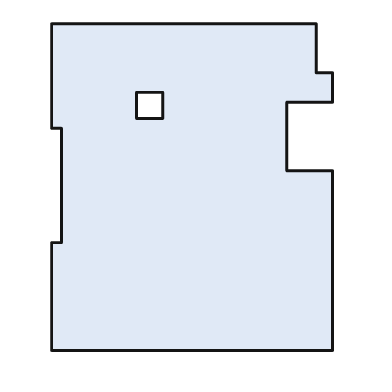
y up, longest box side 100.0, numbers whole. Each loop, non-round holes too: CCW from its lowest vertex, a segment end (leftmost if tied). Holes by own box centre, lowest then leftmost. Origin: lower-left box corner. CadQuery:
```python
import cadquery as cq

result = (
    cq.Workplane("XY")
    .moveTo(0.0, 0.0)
    .lineTo(86.0, 0.0)
    .lineTo(86.0, 55.0)
    .lineTo(72.0, 55.0)
    .lineTo(72.0, 76.0)
    .lineTo(86.0, 76.0)
    .lineTo(86.0, 85.0)
    .lineTo(81.0, 85.0)
    .lineTo(81.0, 100.0)
    .lineTo(0.0, 100.0)
    .lineTo(0.0, 68.0)
    .lineTo(3.0, 68.0)
    .lineTo(3.0, 33.0)
    .lineTo(0.0, 33.0)
    .close()
    .moveTo(26.0, 71.0)
    .lineTo(34.0, 71.0)
    .lineTo(34.0, 79.0)
    .lineTo(26.0, 79.0)
    .close()
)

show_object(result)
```